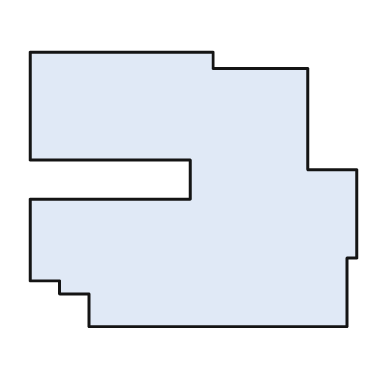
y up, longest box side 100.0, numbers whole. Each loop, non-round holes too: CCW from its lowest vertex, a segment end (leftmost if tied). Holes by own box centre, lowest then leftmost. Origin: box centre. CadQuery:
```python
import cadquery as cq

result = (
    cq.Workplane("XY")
    .moveTo(-32.0, -42.0)
    .lineTo(47.0, -42.0)
    .lineTo(47.0, -21.0)
    .lineTo(50.0, -21.0)
    .lineTo(50.0, 6.0)
    .lineTo(35.0, 6.0)
    .lineTo(35.0, 37.0)
    .lineTo(6.0, 37.0)
    .lineTo(6.0, 42.0)
    .lineTo(-50.0, 42.0)
    .lineTo(-50.0, 9.0)
    .lineTo(-1.0, 9.0)
    .lineTo(-1.0, -3.0)
    .lineTo(-50.0, -3.0)
    .lineTo(-50.0, -28.0)
    .lineTo(-41.0, -28.0)
    .lineTo(-41.0, -32.0)
    .lineTo(-32.0, -32.0)
    .close()
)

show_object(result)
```